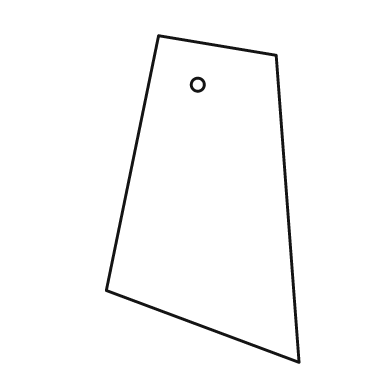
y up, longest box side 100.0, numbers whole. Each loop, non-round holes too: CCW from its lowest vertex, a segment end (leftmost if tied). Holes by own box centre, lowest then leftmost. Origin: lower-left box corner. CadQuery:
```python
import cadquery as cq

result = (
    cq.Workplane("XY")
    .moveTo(59.0, 0.0)
    .lineTo(52.0, 94.0)
    .lineTo(16.0, 100.0)
    .lineTo(0.0, 22.0)
    .close()
    .moveTo(28.0, 85.0)
    .circle(2.0)
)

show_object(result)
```